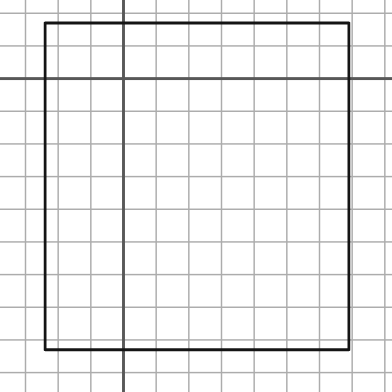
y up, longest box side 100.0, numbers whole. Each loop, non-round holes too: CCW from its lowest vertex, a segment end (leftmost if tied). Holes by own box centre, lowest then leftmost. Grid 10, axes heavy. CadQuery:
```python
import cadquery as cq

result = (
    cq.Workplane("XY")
    .moveTo(-24.0, -83.0)
    .lineTo(69.0, -83.0)
    .lineTo(69.0, 17.0)
    .lineTo(-24.0, 17.0)
    .close()
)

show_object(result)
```